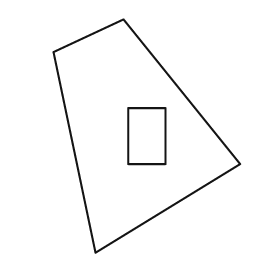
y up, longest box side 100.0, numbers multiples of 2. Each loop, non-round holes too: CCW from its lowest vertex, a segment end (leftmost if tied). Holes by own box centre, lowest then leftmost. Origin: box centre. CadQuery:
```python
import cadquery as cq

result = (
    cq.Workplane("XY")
    .moveTo(-22.0, -50.0)
    .lineTo(40.0, -12.0)
    .lineTo(-10.0, 50.0)
    .lineTo(-40.0, 36.0)
    .close()
    .moveTo(-8.0, -12.0)
    .lineTo(8.0, -12.0)
    .lineTo(8.0, 12.0)
    .lineTo(-8.0, 12.0)
    .close()
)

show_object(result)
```